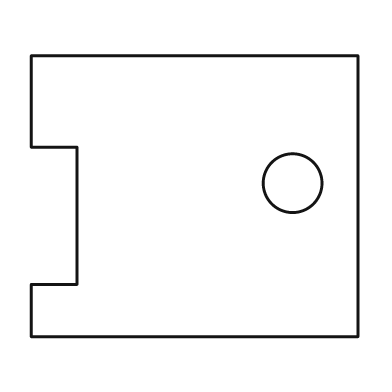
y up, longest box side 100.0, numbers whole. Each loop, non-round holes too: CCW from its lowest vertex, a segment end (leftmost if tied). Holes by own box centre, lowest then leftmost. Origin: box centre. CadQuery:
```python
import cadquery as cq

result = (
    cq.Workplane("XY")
    .moveTo(-50.0, -43.0)
    .lineTo(50.0, -43.0)
    .lineTo(50.0, 43.0)
    .lineTo(-50.0, 43.0)
    .lineTo(-50.0, 15.0)
    .lineTo(-36.0, 15.0)
    .lineTo(-36.0, -27.0)
    .lineTo(-50.0, -27.0)
    .close()
    .moveTo(30.0, 4.0)
    .circle(9.0)
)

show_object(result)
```